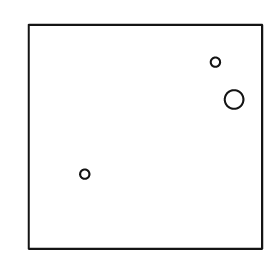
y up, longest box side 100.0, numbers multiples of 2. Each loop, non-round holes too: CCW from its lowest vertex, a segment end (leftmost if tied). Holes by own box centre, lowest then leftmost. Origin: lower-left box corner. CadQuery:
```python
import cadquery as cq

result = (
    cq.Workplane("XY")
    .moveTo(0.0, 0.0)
    .lineTo(100.0, 0.0)
    .lineTo(100.0, 96.0)
    .lineTo(0.0, 96.0)
    .close()
    .moveTo(24.0, 32.0)
    .circle(2.0)
    .moveTo(88.0, 64.0)
    .circle(4.0)
    .moveTo(80.0, 80.0)
    .circle(2.0)
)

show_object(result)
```